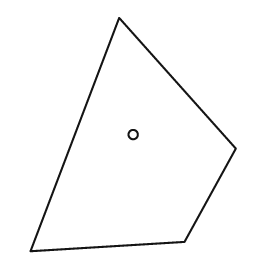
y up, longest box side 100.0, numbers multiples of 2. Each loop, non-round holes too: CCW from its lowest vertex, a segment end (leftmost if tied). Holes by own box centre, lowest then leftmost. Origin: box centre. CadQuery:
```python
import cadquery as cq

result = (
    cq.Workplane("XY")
    .moveTo(-44.0, -50.0)
    .lineTo(22.0, -46.0)
    .lineTo(44.0, -6.0)
    .lineTo(-6.0, 50.0)
    .close()
    .moveTo(0.0, 0.0)
    .circle(2.0)
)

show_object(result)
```